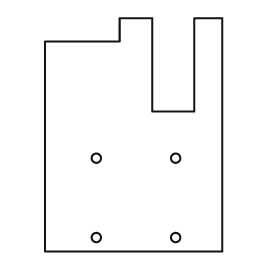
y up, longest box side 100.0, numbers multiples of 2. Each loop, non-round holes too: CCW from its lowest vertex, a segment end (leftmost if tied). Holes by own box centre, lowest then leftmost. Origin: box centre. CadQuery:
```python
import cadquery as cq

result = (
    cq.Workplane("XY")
    .moveTo(-38.0, -50.0)
    .lineTo(38.0, -50.0)
    .lineTo(38.0, 50.0)
    .lineTo(26.0, 50.0)
    .lineTo(26.0, 10.0)
    .lineTo(8.0, 10.0)
    .lineTo(8.0, 50.0)
    .lineTo(-6.0, 50.0)
    .lineTo(-6.0, 40.0)
    .lineTo(-38.0, 40.0)
    .close()
    .moveTo(-16.0, -44.0)
    .circle(2.0)
    .moveTo(18.0, -44.0)
    .circle(2.0)
    .moveTo(-16.0, -10.0)
    .circle(2.0)
    .moveTo(18.0, -10.0)
    .circle(2.0)
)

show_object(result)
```